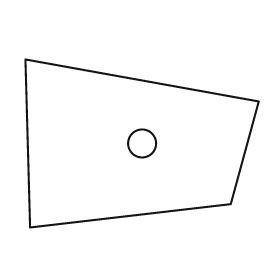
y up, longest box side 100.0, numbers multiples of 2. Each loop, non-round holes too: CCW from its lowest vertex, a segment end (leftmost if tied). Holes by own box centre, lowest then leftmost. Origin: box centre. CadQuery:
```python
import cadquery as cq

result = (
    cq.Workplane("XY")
    .moveTo(-48.0, -36.0)
    .lineTo(38.0, -26.0)
    .lineTo(50.0, 18.0)
    .lineTo(-50.0, 36.0)
    .close()
    .moveTo(0.0, 0.0)
    .circle(6.0)
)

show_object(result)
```